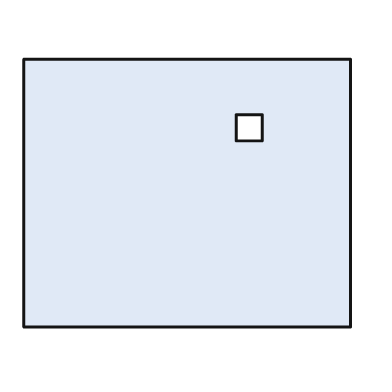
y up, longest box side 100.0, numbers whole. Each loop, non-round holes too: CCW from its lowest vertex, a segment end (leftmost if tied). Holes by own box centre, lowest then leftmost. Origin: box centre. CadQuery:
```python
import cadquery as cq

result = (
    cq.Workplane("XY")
    .moveTo(-50.0, -41.0)
    .lineTo(50.0, -41.0)
    .lineTo(50.0, 41.0)
    .lineTo(-50.0, 41.0)
    .close()
    .moveTo(15.0, 16.0)
    .lineTo(23.0, 16.0)
    .lineTo(23.0, 24.0)
    .lineTo(15.0, 24.0)
    .close()
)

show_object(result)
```